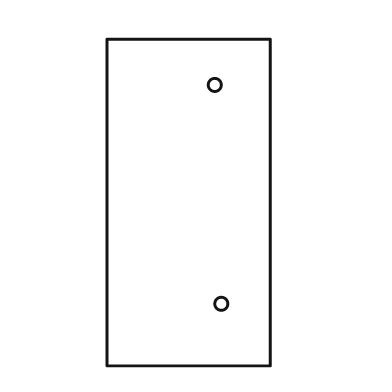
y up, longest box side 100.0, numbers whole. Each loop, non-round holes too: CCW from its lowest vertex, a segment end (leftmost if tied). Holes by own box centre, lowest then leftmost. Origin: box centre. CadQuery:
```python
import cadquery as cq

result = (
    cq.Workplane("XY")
    .moveTo(-25.0, -50.0)
    .lineTo(25.0, -50.0)
    .lineTo(25.0, 50.0)
    .lineTo(-25.0, 50.0)
    .close()
    .moveTo(10.0, -31.0)
    .circle(2.0)
    .moveTo(8.0, 36.0)
    .circle(2.0)
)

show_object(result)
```